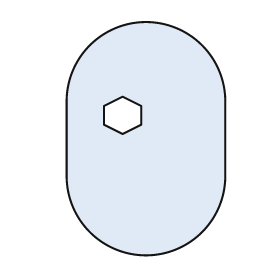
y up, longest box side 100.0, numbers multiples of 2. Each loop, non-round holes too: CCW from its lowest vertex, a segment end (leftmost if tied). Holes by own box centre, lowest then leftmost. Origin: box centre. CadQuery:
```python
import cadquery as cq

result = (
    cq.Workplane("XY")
    .moveTo(-34.0, -16.0)
    .threePointArc((0.0, -50.0), (34.0, -16.0))
    .lineTo(34.0, 16.0)
    .threePointArc((0.0, 50.0), (-34.0, 16.0))
    .close()
    .moveTo(-10.0, 2.0)
    .lineTo(-2.0, 6.0)
    .lineTo(-2.0, 14.0)
    .lineTo(-10.0, 18.0)
    .lineTo(-18.0, 14.0)
    .lineTo(-18.0, 6.0)
    .close()
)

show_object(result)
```